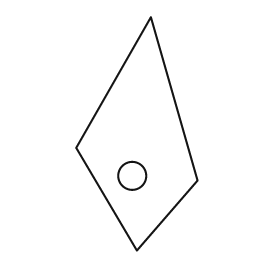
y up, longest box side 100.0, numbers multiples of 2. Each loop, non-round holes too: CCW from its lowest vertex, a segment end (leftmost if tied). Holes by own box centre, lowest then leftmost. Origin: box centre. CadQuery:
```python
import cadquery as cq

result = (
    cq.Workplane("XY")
    .moveTo(0.0, -50.0)
    .lineTo(26.0, -20.0)
    .lineTo(6.0, 50.0)
    .lineTo(-26.0, -6.0)
    .close()
    .moveTo(-2.0, -18.0)
    .circle(6.0)
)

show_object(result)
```